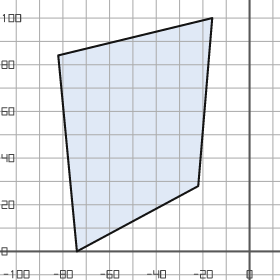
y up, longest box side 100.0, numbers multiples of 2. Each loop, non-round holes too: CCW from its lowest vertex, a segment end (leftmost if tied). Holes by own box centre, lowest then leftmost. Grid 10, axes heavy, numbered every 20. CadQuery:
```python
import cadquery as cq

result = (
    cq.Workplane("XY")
    .moveTo(-74.0, 0.0)
    .lineTo(-22.0, 28.0)
    .lineTo(-16.0, 100.0)
    .lineTo(-82.0, 84.0)
    .close()
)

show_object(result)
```